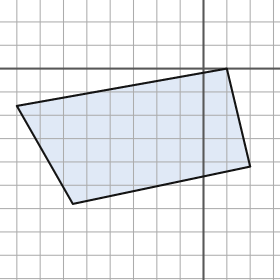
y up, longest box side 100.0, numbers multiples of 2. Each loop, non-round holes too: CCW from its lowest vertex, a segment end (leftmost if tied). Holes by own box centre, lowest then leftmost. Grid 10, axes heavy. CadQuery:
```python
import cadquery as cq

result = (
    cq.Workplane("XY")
    .moveTo(-56.0, -58.0)
    .lineTo(20.0, -42.0)
    .lineTo(10.0, 0.0)
    .lineTo(-80.0, -16.0)
    .close()
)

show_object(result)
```